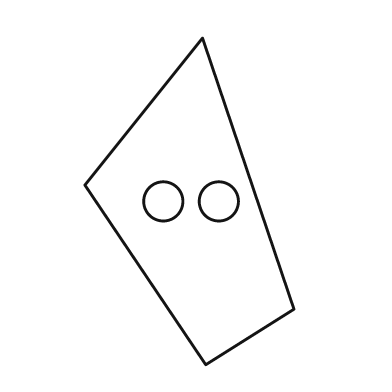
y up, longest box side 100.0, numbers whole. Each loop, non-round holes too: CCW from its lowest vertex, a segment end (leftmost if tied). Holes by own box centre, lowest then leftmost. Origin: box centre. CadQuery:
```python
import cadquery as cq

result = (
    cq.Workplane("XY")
    .moveTo(5.0, -50.0)
    .lineTo(32.0, -33.0)
    .lineTo(4.0, 50.0)
    .lineTo(-32.0, 5.0)
    .close()
    .moveTo(-8.0, 0.0)
    .circle(6.0)
    .moveTo(9.0, 0.0)
    .circle(6.0)
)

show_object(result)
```